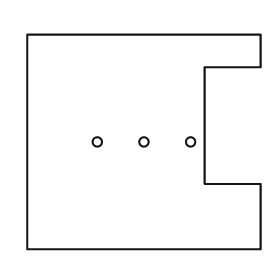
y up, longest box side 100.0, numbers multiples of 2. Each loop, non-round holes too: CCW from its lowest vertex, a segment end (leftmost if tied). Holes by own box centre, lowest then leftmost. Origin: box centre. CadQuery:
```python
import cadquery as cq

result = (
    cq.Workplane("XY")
    .moveTo(-50.0, -46.0)
    .lineTo(50.0, -46.0)
    .lineTo(50.0, -18.0)
    .lineTo(26.0, -18.0)
    .lineTo(26.0, 32.0)
    .lineTo(50.0, 32.0)
    .lineTo(50.0, 46.0)
    .lineTo(-50.0, 46.0)
    .close()
    .moveTo(-20.0, 0.0)
    .circle(2.0)
    .moveTo(0.0, 0.0)
    .circle(2.0)
    .moveTo(20.0, 0.0)
    .circle(2.0)
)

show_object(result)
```